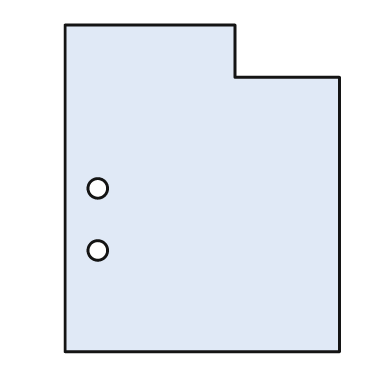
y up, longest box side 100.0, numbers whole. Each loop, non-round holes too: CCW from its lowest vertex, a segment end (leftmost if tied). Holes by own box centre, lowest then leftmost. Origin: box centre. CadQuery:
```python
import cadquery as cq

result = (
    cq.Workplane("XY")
    .moveTo(-42.0, -50.0)
    .lineTo(42.0, -50.0)
    .lineTo(42.0, 34.0)
    .lineTo(10.0, 34.0)
    .lineTo(10.0, 50.0)
    .lineTo(-42.0, 50.0)
    .close()
    .moveTo(-32.0, -19.0)
    .circle(3.0)
    .moveTo(-32.0, 0.0)
    .circle(3.0)
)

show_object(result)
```